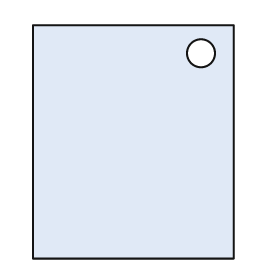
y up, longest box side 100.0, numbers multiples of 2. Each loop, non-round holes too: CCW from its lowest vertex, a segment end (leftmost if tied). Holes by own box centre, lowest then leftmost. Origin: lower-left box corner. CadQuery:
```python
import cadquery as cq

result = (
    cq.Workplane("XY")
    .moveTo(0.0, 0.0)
    .lineTo(86.0, 0.0)
    .lineTo(86.0, 100.0)
    .lineTo(0.0, 100.0)
    .close()
    .moveTo(72.0, 88.0)
    .circle(6.0)
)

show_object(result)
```